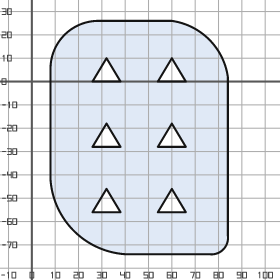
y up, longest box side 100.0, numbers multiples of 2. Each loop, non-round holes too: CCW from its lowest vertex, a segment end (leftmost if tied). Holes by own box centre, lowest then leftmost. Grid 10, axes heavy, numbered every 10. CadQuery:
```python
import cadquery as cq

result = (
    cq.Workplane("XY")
    .moveTo(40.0, -74.0)
    .lineTo(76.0, -74.0)
    .threePointArc((82.0, -72.0), (84.0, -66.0))
    .lineTo(84.0, 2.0)
    .threePointArc((76.0, 18.0), (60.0, 26.0))
    .lineTo(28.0, 26.0)
    .threePointArc((14.0, 20.0), (8.0, 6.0))
    .lineTo(8.0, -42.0)
    .threePointArc((18.0, -64.0), (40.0, -74.0))
    .close()
    .moveTo(26.0, -56.0)
    .lineTo(38.0, -56.0)
    .lineTo(32.0, -46.0)
    .close()
    .moveTo(54.0, -56.0)
    .lineTo(66.0, -56.0)
    .lineTo(60.0, -46.0)
    .close()
    .moveTo(26.0, -28.0)
    .lineTo(38.0, -28.0)
    .lineTo(32.0, -18.0)
    .close()
    .moveTo(54.0, -28.0)
    .lineTo(66.0, -28.0)
    .lineTo(60.0, -18.0)
    .close()
    .moveTo(26.0, 0.0)
    .lineTo(38.0, 0.0)
    .lineTo(32.0, 10.0)
    .close()
    .moveTo(54.0, 0.0)
    .lineTo(66.0, 0.0)
    .lineTo(60.0, 10.0)
    .close()
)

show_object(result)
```